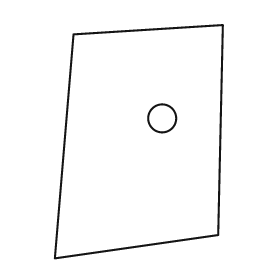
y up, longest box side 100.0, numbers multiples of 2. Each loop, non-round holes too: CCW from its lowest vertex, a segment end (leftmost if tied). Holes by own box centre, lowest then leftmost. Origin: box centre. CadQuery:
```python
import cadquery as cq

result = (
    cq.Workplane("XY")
    .moveTo(-36.0, -50.0)
    .lineTo(34.0, -40.0)
    .lineTo(36.0, 50.0)
    .lineTo(-28.0, 46.0)
    .close()
    .moveTo(10.0, 10.0)
    .circle(6.0)
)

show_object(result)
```